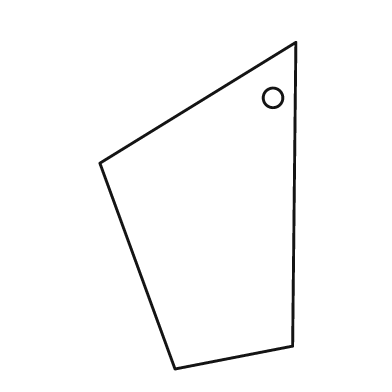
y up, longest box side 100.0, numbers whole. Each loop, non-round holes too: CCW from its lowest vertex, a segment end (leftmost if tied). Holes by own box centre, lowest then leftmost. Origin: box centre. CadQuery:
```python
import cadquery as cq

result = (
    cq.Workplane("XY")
    .moveTo(-7.0, -50.0)
    .lineTo(29.0, -43.0)
    .lineTo(30.0, 50.0)
    .lineTo(-30.0, 13.0)
    .close()
    .moveTo(23.0, 33.0)
    .circle(3.0)
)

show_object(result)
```